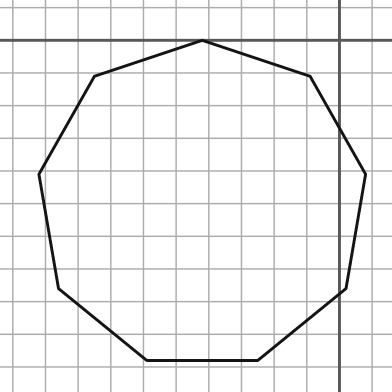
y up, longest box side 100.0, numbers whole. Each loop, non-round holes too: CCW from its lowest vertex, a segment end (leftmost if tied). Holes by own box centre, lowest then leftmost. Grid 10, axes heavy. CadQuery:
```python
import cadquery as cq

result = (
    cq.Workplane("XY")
    .moveTo(-59.0, -98.0)
    .lineTo(-25.0, -98.0)
    .lineTo(2.0, -76.0)
    .lineTo(8.0, -41.0)
    .lineTo(-9.0, -11.0)
    .lineTo(-42.0, 0.0)
    .lineTo(-75.0, -11.0)
    .lineTo(-92.0, -41.0)
    .lineTo(-86.0, -76.0)
    .close()
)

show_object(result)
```